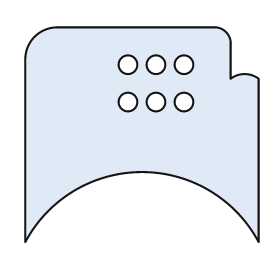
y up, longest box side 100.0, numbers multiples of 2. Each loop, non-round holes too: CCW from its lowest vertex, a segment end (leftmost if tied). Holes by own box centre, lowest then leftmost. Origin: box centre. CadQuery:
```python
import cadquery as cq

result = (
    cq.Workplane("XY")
    .moveTo(-50.0, -46.0)
    .threePointArc((0.0, -16.0), (50.0, -46.0))
    .lineTo(50.0, 24.0)
    .threePointArc((44.0, 26.0), (38.0, 24.0))
    .lineTo(38.0, 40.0)
    .threePointArc((36.0, 44.0), (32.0, 46.0))
    .lineTo(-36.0, 46.0)
    .threePointArc((-46.0, 42.0), (-50.0, 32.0))
    .close()
    .moveTo(-6.0, 14.0)
    .circle(4.0)
    .moveTo(6.0, 14.0)
    .circle(4.0)
    .moveTo(18.0, 14.0)
    .circle(4.0)
    .moveTo(-6.0, 30.0)
    .circle(4.0)
    .moveTo(6.0, 30.0)
    .circle(4.0)
    .moveTo(18.0, 30.0)
    .circle(4.0)
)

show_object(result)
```